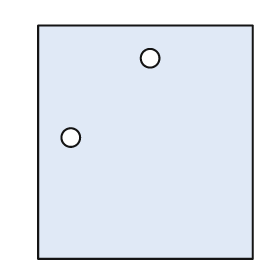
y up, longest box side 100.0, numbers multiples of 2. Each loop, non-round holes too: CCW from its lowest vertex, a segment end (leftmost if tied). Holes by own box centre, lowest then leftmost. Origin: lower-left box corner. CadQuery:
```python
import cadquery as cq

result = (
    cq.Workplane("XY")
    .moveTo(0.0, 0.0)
    .lineTo(92.0, 0.0)
    .lineTo(92.0, 100.0)
    .lineTo(0.0, 100.0)
    .close()
    .moveTo(14.0, 52.0)
    .circle(4.0)
    .moveTo(48.0, 86.0)
    .circle(4.0)
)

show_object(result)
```